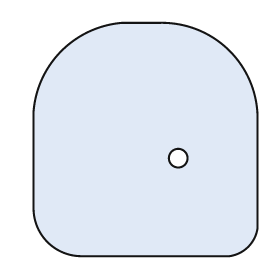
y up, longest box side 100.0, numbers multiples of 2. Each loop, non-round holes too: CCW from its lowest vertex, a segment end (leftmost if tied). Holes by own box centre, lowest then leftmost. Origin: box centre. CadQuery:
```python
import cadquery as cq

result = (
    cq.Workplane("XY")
    .moveTo(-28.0, -50.0)
    .lineTo(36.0, -50.0)
    .threePointArc((44.0, -46.0), (48.0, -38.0))
    .lineTo(48.0, 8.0)
    .threePointArc((36.0, 38.0), (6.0, 50.0))
    .lineTo(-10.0, 50.0)
    .threePointArc((-36.0, 38.0), (-48.0, 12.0))
    .lineTo(-48.0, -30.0)
    .threePointArc((-42.0, -44.0), (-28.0, -50.0))
    .close()
    .moveTo(14.0, -8.0)
    .circle(4.0)
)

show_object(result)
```